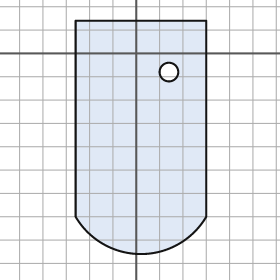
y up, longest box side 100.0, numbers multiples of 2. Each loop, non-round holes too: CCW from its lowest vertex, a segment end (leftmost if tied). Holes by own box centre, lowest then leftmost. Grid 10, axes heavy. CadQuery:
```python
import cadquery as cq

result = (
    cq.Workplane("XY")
    .moveTo(-26.0, -70.0)
    .threePointArc((2.0, -86.0), (30.0, -70.0))
    .lineTo(30.0, 14.0)
    .lineTo(-26.0, 14.0)
    .close()
    .moveTo(14.0, -8.0)
    .circle(4.0)
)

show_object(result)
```